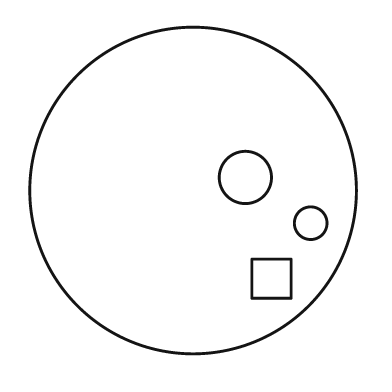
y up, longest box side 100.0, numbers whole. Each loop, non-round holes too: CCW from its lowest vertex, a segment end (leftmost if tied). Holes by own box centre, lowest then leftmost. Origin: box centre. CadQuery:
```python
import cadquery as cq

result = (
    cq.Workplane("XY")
    .moveTo(0.0, 0.0)
    .circle(50.0)
    .moveTo(18.0, -33.0)
    .lineTo(30.0, -33.0)
    .lineTo(30.0, -21.0)
    .lineTo(18.0, -21.0)
    .close()
    .moveTo(36.0, -10.0)
    .circle(5.0)
    .moveTo(16.0, 4.0)
    .circle(8.0)
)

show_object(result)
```